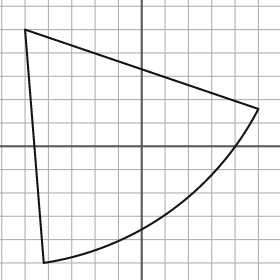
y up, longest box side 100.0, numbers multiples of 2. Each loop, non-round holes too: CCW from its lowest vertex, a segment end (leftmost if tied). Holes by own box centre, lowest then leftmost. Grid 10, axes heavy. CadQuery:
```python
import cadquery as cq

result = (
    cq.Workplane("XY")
    .moveTo(-42.0, -50.0)
    .threePointArc((12.0, -28.0), (50.0, 16.0))
    .lineTo(-50.0, 50.0)
    .close()
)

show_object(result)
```